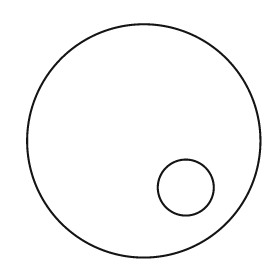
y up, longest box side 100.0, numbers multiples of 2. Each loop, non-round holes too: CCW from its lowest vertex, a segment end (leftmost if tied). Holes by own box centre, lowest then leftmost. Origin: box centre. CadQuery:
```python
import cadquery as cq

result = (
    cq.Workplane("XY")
    .moveTo(0.0, 0.0)
    .circle(50.0)
    .moveTo(18.0, -20.0)
    .circle(12.0)
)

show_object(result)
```